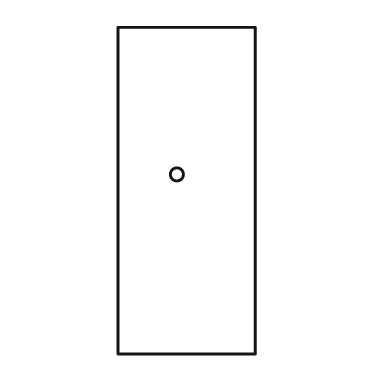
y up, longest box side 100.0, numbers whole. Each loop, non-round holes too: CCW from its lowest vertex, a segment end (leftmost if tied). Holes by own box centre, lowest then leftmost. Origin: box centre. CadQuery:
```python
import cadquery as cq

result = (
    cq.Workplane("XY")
    .moveTo(-21.0, -50.0)
    .lineTo(21.0, -50.0)
    .lineTo(21.0, 50.0)
    .lineTo(-21.0, 50.0)
    .close()
    .moveTo(-3.0, 5.0)
    .circle(2.0)
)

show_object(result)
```